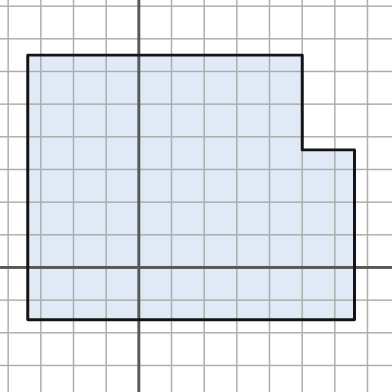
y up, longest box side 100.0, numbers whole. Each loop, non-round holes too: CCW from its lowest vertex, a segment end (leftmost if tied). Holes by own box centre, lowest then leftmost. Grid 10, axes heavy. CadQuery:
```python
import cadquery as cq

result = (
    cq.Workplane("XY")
    .moveTo(-34.0, -16.0)
    .lineTo(66.0, -16.0)
    .lineTo(66.0, 36.0)
    .lineTo(50.0, 36.0)
    .lineTo(50.0, 65.0)
    .lineTo(-34.0, 65.0)
    .close()
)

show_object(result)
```